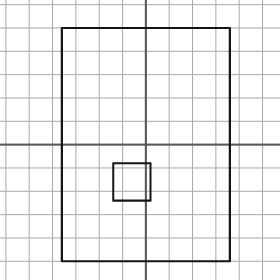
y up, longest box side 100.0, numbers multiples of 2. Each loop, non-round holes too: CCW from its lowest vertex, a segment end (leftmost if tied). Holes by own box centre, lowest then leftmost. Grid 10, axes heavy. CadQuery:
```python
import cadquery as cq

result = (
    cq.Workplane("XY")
    .moveTo(-36.0, -50.0)
    .lineTo(36.0, -50.0)
    .lineTo(36.0, 50.0)
    .lineTo(-36.0, 50.0)
    .close()
    .moveTo(-14.0, -24.0)
    .lineTo(2.0, -24.0)
    .lineTo(2.0, -8.0)
    .lineTo(-14.0, -8.0)
    .close()
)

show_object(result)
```